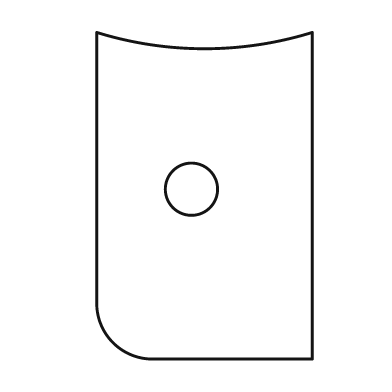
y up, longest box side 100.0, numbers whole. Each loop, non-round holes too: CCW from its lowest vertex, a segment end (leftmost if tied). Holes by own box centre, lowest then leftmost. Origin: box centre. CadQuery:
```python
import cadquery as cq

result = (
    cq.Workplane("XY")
    .moveTo(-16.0, -50.0)
    .lineTo(33.0, -50.0)
    .lineTo(33.0, 50.0)
    .threePointArc((0.0, 45.0), (-33.0, 50.0))
    .lineTo(-33.0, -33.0)
    .threePointArc((-28.0, -45.0), (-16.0, -50.0))
    .close()
    .moveTo(-4.0, 2.0)
    .circle(8.0)
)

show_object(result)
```